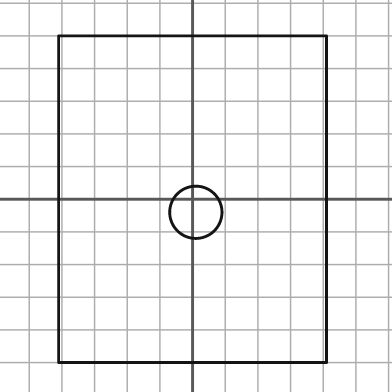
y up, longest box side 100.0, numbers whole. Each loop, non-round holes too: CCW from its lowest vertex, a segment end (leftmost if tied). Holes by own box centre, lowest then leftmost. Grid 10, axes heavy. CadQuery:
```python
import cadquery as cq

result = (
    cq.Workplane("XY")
    .moveTo(-41.0, -50.0)
    .lineTo(41.0, -50.0)
    .lineTo(41.0, 50.0)
    .lineTo(-41.0, 50.0)
    .close()
    .moveTo(1.0, -4.0)
    .circle(8.0)
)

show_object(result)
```